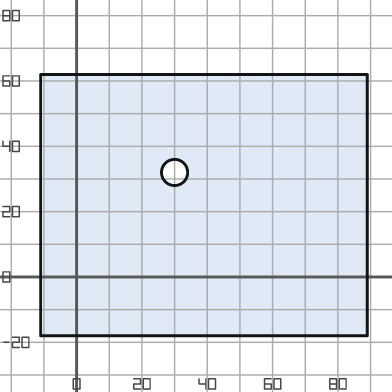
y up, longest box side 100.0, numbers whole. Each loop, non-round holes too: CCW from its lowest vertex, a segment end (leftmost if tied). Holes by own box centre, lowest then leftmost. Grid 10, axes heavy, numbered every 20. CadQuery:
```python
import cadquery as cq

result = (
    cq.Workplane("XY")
    .moveTo(-11.0, -18.0)
    .lineTo(89.0, -18.0)
    .lineTo(89.0, 62.0)
    .lineTo(-11.0, 62.0)
    .close()
    .moveTo(30.0, 32.0)
    .circle(4.0)
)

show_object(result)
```